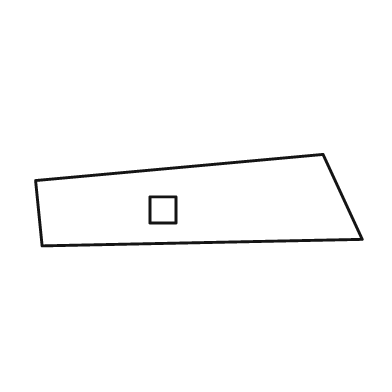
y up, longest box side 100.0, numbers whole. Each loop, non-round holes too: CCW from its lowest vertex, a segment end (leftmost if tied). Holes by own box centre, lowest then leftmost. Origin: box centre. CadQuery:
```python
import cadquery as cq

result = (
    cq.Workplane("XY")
    .moveTo(-48.0, -14.0)
    .lineTo(50.0, -12.0)
    .lineTo(38.0, 14.0)
    .lineTo(-50.0, 6.0)
    .close()
    .moveTo(-15.0, -7.0)
    .lineTo(-7.0, -7.0)
    .lineTo(-7.0, 1.0)
    .lineTo(-15.0, 1.0)
    .close()
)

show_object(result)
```